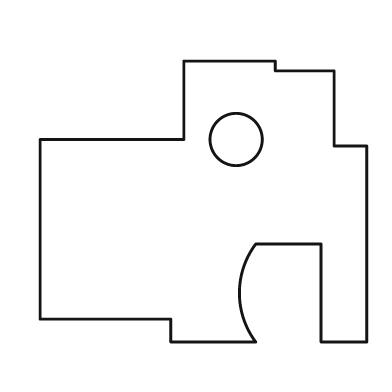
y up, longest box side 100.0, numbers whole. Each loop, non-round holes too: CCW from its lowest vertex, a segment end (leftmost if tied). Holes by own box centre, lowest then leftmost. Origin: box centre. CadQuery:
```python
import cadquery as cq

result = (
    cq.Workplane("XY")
    .moveTo(-10.0, -43.0)
    .lineTo(16.0, -43.0)
    .threePointArc((11.0, -28.0), (16.0, -13.0))
    .lineTo(36.0, -13.0)
    .lineTo(36.0, -43.0)
    .lineTo(50.0, -43.0)
    .lineTo(50.0, 17.0)
    .lineTo(40.0, 17.0)
    .lineTo(40.0, 40.0)
    .lineTo(22.0, 40.0)
    .lineTo(22.0, 43.0)
    .lineTo(-6.0, 43.0)
    .lineTo(-6.0, 19.0)
    .lineTo(-50.0, 19.0)
    .lineTo(-50.0, -36.0)
    .lineTo(-10.0, -36.0)
    .close()
    .moveTo(10.0, 19.0)
    .circle(8.0)
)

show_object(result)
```